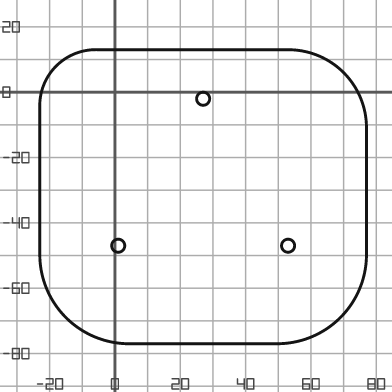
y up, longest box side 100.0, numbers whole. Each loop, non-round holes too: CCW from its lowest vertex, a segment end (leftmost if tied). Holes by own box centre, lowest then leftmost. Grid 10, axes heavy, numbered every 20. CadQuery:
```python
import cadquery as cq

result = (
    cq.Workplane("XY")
    .moveTo(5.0, -77.0)
    .lineTo(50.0, -77.0)
    .threePointArc((69.0, -69.0), (77.0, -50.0))
    .lineTo(77.0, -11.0)
    .threePointArc((70.0, 6.0), (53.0, 13.0))
    .lineTo(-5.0, 13.0)
    .threePointArc((-18.0, 8.0), (-23.0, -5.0))
    .lineTo(-23.0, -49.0)
    .threePointArc((-15.0, -69.0), (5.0, -77.0))
    .close()
    .moveTo(1.0, -47.0)
    .circle(2.0)
    .moveTo(53.0, -47.0)
    .circle(2.0)
    .moveTo(27.0, -2.0)
    .circle(2.0)
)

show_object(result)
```